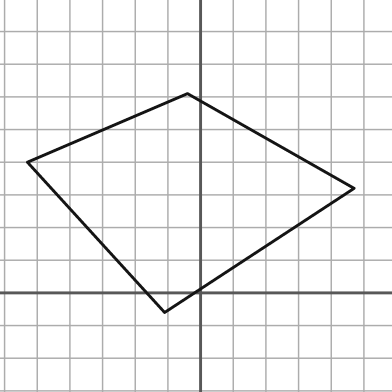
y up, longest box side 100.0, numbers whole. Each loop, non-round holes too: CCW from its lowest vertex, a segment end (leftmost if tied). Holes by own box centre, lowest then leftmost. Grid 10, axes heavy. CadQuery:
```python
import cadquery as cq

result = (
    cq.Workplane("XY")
    .moveTo(-11.0, -6.0)
    .lineTo(47.0, 32.0)
    .lineTo(-4.0, 61.0)
    .lineTo(-53.0, 40.0)
    .close()
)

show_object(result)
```